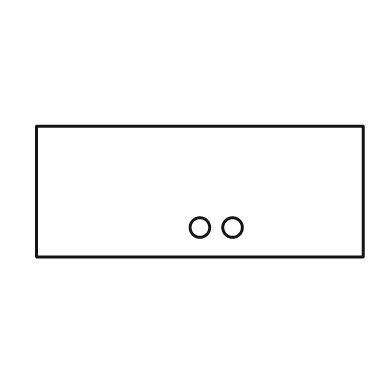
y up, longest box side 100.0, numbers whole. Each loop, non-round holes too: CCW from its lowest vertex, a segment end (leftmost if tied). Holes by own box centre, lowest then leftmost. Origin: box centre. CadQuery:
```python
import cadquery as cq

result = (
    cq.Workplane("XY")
    .moveTo(-50.0, -20.0)
    .lineTo(50.0, -20.0)
    .lineTo(50.0, 20.0)
    .lineTo(-50.0, 20.0)
    .close()
    .moveTo(0.0, -11.0)
    .circle(3.0)
    .moveTo(10.0, -11.0)
    .circle(3.0)
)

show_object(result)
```